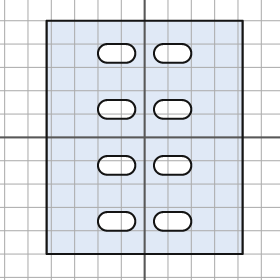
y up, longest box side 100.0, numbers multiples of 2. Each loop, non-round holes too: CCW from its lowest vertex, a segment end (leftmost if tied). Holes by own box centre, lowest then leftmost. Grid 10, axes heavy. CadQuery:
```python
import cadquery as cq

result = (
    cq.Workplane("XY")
    .moveTo(-42.0, -50.0)
    .lineTo(42.0, -50.0)
    .lineTo(42.0, 50.0)
    .lineTo(-42.0, 50.0)
    .close()
    .moveTo(-16.0, -40.0)
    .lineTo(-8.0, -40.0)
    .threePointArc((-4.0, -36.0), (-8.0, -32.0))
    .lineTo(-16.0, -32.0)
    .threePointArc((-20.0, -36.0), (-16.0, -40.0))
    .close()
    .moveTo(8.0, -40.0)
    .lineTo(16.0, -40.0)
    .threePointArc((20.0, -36.0), (16.0, -32.0))
    .lineTo(8.0, -32.0)
    .threePointArc((4.0, -36.0), (8.0, -40.0))
    .close()
    .moveTo(-16.0, -16.0)
    .lineTo(-8.0, -16.0)
    .threePointArc((-4.0, -12.0), (-8.0, -8.0))
    .lineTo(-16.0, -8.0)
    .threePointArc((-20.0, -12.0), (-16.0, -16.0))
    .close()
    .moveTo(8.0, -16.0)
    .lineTo(16.0, -16.0)
    .threePointArc((20.0, -12.0), (16.0, -8.0))
    .lineTo(8.0, -8.0)
    .threePointArc((4.0, -12.0), (8.0, -16.0))
    .close()
    .moveTo(-16.0, 8.0)
    .lineTo(-8.0, 8.0)
    .threePointArc((-4.0, 12.0), (-8.0, 16.0))
    .lineTo(-16.0, 16.0)
    .threePointArc((-20.0, 12.0), (-16.0, 8.0))
    .close()
    .moveTo(8.0, 8.0)
    .lineTo(16.0, 8.0)
    .threePointArc((20.0, 12.0), (16.0, 16.0))
    .lineTo(8.0, 16.0)
    .threePointArc((4.0, 12.0), (8.0, 8.0))
    .close()
    .moveTo(-16.0, 32.0)
    .lineTo(-8.0, 32.0)
    .threePointArc((-4.0, 36.0), (-8.0, 40.0))
    .lineTo(-16.0, 40.0)
    .threePointArc((-20.0, 36.0), (-16.0, 32.0))
    .close()
    .moveTo(8.0, 32.0)
    .lineTo(16.0, 32.0)
    .threePointArc((20.0, 36.0), (16.0, 40.0))
    .lineTo(8.0, 40.0)
    .threePointArc((4.0, 36.0), (8.0, 32.0))
    .close()
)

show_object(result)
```